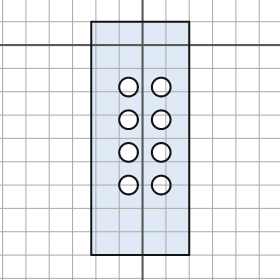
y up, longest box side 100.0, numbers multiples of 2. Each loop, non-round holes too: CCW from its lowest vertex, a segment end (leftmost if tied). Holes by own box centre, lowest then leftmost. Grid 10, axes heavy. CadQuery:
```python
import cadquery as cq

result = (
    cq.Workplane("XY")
    .moveTo(-22.0, -90.0)
    .lineTo(20.0, -90.0)
    .lineTo(20.0, 10.0)
    .lineTo(-22.0, 10.0)
    .close()
    .moveTo(-6.0, -60.0)
    .circle(4.0)
    .moveTo(8.0, -60.0)
    .circle(4.0)
    .moveTo(-6.0, -46.0)
    .circle(4.0)
    .moveTo(8.0, -46.0)
    .circle(4.0)
    .moveTo(-6.0, -32.0)
    .circle(4.0)
    .moveTo(8.0, -32.0)
    .circle(4.0)
    .moveTo(-6.0, -18.0)
    .circle(4.0)
    .moveTo(8.0, -18.0)
    .circle(4.0)
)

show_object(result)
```